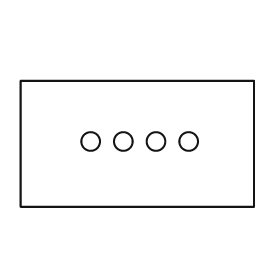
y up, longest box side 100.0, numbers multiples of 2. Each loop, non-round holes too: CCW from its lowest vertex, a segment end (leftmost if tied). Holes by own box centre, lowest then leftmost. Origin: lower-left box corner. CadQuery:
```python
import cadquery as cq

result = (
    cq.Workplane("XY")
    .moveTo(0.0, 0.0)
    .lineTo(100.0, 0.0)
    .lineTo(100.0, 54.0)
    .lineTo(0.0, 54.0)
    .close()
    .moveTo(30.0, 28.0)
    .circle(4.0)
    .moveTo(44.0, 28.0)
    .circle(4.0)
    .moveTo(58.0, 28.0)
    .circle(4.0)
    .moveTo(72.0, 28.0)
    .circle(4.0)
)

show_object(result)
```